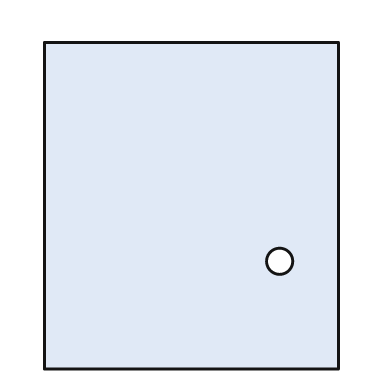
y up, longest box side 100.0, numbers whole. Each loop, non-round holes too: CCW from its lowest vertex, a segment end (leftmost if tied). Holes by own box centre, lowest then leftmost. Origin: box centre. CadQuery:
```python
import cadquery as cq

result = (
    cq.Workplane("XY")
    .moveTo(-45.0, -50.0)
    .lineTo(45.0, -50.0)
    .lineTo(45.0, 50.0)
    .lineTo(-45.0, 50.0)
    .close()
    .moveTo(27.0, -17.0)
    .circle(4.0)
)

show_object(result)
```